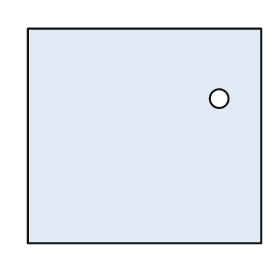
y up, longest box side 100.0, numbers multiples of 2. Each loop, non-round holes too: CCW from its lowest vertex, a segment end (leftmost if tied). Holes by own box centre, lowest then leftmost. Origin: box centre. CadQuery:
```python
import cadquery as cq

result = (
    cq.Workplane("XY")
    .moveTo(-50.0, -46.0)
    .lineTo(50.0, -46.0)
    .lineTo(50.0, 46.0)
    .lineTo(-50.0, 46.0)
    .close()
    .moveTo(32.0, 16.0)
    .circle(4.0)
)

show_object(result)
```